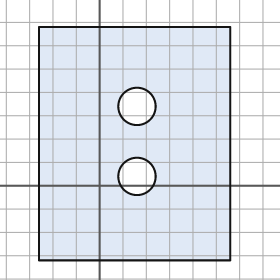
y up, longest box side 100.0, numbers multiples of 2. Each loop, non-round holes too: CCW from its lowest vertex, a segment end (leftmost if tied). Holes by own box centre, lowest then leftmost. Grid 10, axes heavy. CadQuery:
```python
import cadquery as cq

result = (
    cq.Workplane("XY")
    .moveTo(-26.0, -32.0)
    .lineTo(56.0, -32.0)
    .lineTo(56.0, 68.0)
    .lineTo(-26.0, 68.0)
    .close()
    .moveTo(16.0, 4.0)
    .circle(8.0)
    .moveTo(16.0, 34.0)
    .circle(8.0)
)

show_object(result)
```